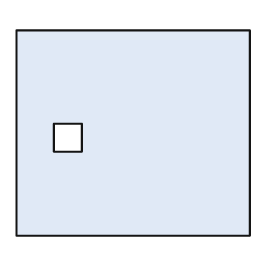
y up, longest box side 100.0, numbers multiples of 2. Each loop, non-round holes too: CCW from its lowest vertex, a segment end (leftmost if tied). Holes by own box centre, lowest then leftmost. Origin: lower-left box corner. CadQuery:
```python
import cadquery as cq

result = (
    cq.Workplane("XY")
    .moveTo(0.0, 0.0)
    .lineTo(100.0, 0.0)
    .lineTo(100.0, 88.0)
    .lineTo(0.0, 88.0)
    .close()
    .moveTo(16.0, 36.0)
    .lineTo(28.0, 36.0)
    .lineTo(28.0, 48.0)
    .lineTo(16.0, 48.0)
    .close()
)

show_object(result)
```